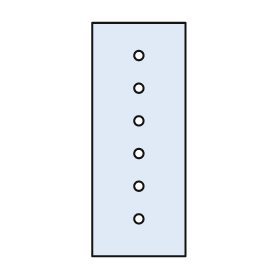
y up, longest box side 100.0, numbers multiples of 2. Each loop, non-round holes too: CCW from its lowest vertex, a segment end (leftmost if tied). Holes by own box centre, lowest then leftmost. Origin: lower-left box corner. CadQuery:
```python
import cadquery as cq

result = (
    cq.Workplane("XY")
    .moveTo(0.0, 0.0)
    .lineTo(40.0, 0.0)
    .lineTo(40.0, 100.0)
    .lineTo(0.0, 100.0)
    .close()
    .moveTo(20.0, 16.0)
    .circle(2.0)
    .moveTo(20.0, 30.0)
    .circle(2.0)
    .moveTo(20.0, 44.0)
    .circle(2.0)
    .moveTo(20.0, 58.0)
    .circle(2.0)
    .moveTo(20.0, 72.0)
    .circle(2.0)
    .moveTo(20.0, 86.0)
    .circle(2.0)
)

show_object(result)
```